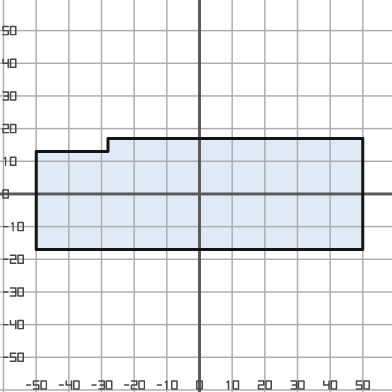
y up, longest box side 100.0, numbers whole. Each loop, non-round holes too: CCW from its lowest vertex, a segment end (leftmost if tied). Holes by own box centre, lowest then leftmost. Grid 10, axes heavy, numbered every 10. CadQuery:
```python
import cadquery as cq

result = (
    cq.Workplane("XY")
    .moveTo(-50.0, -17.0)
    .lineTo(50.0, -17.0)
    .lineTo(50.0, 17.0)
    .lineTo(-28.0, 17.0)
    .lineTo(-28.0, 13.0)
    .lineTo(-50.0, 13.0)
    .close()
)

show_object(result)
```